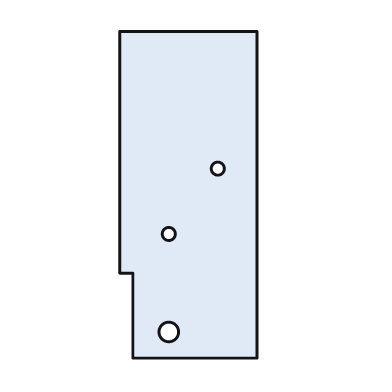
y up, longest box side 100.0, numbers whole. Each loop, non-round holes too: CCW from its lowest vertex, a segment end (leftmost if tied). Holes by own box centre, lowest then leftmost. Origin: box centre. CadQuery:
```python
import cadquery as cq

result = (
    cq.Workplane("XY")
    .moveTo(-17.0, -50.0)
    .lineTo(21.0, -50.0)
    .lineTo(21.0, 50.0)
    .lineTo(-21.0, 50.0)
    .lineTo(-21.0, -24.0)
    .lineTo(-17.0, -24.0)
    .close()
    .moveTo(-6.0, -42.0)
    .circle(3.0)
    .moveTo(-6.0, -12.0)
    .circle(2.0)
    .moveTo(9.0, 8.0)
    .circle(2.0)
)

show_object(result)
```